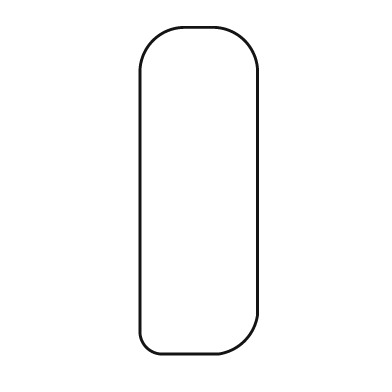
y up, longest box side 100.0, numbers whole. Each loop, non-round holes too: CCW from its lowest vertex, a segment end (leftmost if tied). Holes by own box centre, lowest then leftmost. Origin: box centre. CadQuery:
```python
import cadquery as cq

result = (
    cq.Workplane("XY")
    .moveTo(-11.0, -50.0)
    .lineTo(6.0, -50.0)
    .threePointArc((14.0, -46.0), (18.0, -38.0))
    .lineTo(18.0, 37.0)
    .threePointArc((14.0, 46.0), (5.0, 50.0))
    .lineTo(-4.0, 50.0)
    .threePointArc((-14.0, 46.0), (-18.0, 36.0))
    .lineTo(-18.0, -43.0)
    .threePointArc((-16.0, -48.0), (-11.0, -50.0))
    .close()
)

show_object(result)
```